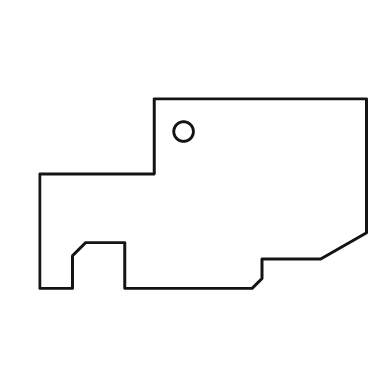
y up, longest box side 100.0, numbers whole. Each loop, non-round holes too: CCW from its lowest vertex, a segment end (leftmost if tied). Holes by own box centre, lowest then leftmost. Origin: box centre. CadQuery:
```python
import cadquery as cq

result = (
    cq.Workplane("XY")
    .moveTo(-50.0, -29.0)
    .lineTo(-40.0, -29.0)
    .lineTo(-40.0, -19.0)
    .lineTo(-36.0, -15.0)
    .lineTo(-24.0, -15.0)
    .lineTo(-24.0, -29.0)
    .lineTo(15.0, -29.0)
    .lineTo(18.0, -26.0)
    .lineTo(18.0, -20.0)
    .lineTo(36.0, -20.0)
    .lineTo(50.0, -12.0)
    .lineTo(50.0, 29.0)
    .lineTo(-15.0, 29.0)
    .lineTo(-15.0, 6.0)
    .lineTo(-50.0, 6.0)
    .close()
    .moveTo(-6.0, 19.0)
    .circle(3.0)
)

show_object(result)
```